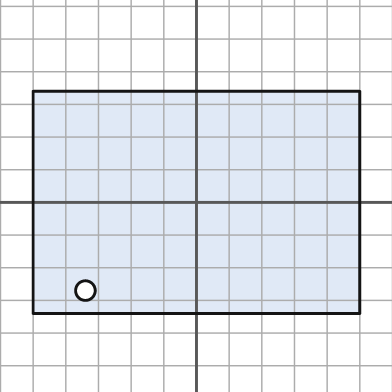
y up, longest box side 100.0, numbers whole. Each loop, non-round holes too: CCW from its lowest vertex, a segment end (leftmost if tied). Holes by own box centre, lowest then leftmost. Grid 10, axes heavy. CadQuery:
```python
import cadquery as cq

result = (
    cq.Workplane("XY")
    .moveTo(-50.0, -34.0)
    .lineTo(50.0, -34.0)
    .lineTo(50.0, 34.0)
    .lineTo(-50.0, 34.0)
    .close()
    .moveTo(-34.0, -27.0)
    .circle(3.0)
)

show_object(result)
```